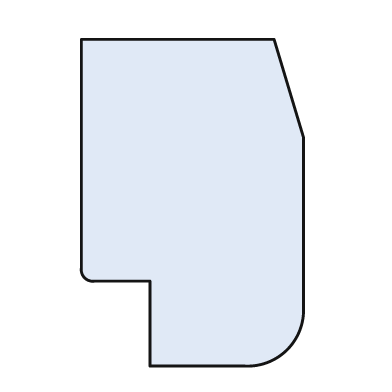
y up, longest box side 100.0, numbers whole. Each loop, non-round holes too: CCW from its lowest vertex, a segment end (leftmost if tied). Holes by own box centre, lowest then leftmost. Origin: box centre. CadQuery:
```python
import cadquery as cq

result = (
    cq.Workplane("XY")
    .moveTo(-13.0, -50.0)
    .lineTo(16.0, -50.0)
    .threePointArc((29.0, -45.0), (34.0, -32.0))
    .lineTo(34.0, 20.0)
    .lineTo(25.0, 50.0)
    .lineTo(-34.0, 50.0)
    .lineTo(-34.0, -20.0)
    .threePointArc((-33.0, -23.0), (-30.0, -24.0))
    .lineTo(-13.0, -24.0)
    .close()
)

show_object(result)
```